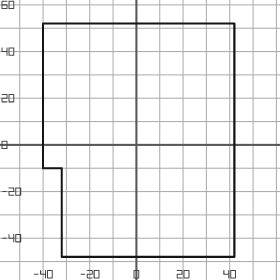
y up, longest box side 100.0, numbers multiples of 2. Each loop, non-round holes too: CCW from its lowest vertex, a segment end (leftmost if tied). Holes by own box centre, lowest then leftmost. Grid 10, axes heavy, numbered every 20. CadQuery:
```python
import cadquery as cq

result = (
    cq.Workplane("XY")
    .moveTo(-32.0, -48.0)
    .lineTo(42.0, -48.0)
    .lineTo(42.0, 52.0)
    .lineTo(-40.0, 52.0)
    .lineTo(-40.0, -10.0)
    .lineTo(-32.0, -10.0)
    .close()
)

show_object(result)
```